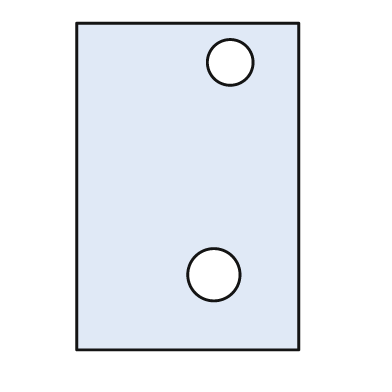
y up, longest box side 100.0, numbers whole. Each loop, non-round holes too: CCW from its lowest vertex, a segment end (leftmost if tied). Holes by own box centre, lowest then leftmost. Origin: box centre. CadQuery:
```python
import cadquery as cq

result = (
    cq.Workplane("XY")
    .moveTo(-34.0, -50.0)
    .lineTo(34.0, -50.0)
    .lineTo(34.0, 50.0)
    .lineTo(-34.0, 50.0)
    .close()
    .moveTo(8.0, -27.0)
    .circle(8.0)
    .moveTo(13.0, 38.0)
    .circle(7.0)
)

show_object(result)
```